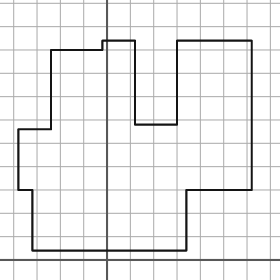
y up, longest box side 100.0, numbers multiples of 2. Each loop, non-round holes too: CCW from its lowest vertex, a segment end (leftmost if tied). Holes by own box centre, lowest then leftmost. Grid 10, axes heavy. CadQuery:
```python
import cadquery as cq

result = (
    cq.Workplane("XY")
    .moveTo(-32.0, 4.0)
    .lineTo(34.0, 4.0)
    .lineTo(34.0, 30.0)
    .lineTo(62.0, 30.0)
    .lineTo(62.0, 94.0)
    .lineTo(30.0, 94.0)
    .lineTo(30.0, 58.0)
    .lineTo(12.0, 58.0)
    .lineTo(12.0, 94.0)
    .lineTo(-2.0, 94.0)
    .lineTo(-2.0, 90.0)
    .lineTo(-24.0, 90.0)
    .lineTo(-24.0, 56.0)
    .lineTo(-38.0, 56.0)
    .lineTo(-38.0, 30.0)
    .lineTo(-32.0, 30.0)
    .close()
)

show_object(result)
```